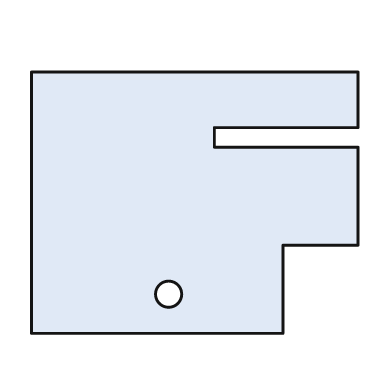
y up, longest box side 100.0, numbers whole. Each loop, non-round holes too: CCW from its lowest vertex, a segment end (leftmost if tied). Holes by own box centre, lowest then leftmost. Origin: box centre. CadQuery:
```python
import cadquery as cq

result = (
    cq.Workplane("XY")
    .moveTo(-50.0, -40.0)
    .lineTo(27.0, -40.0)
    .lineTo(27.0, -13.0)
    .lineTo(50.0, -13.0)
    .lineTo(50.0, 17.0)
    .lineTo(6.0, 17.0)
    .lineTo(6.0, 23.0)
    .lineTo(50.0, 23.0)
    .lineTo(50.0, 40.0)
    .lineTo(-50.0, 40.0)
    .close()
    .moveTo(-8.0, -28.0)
    .circle(4.0)
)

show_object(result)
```